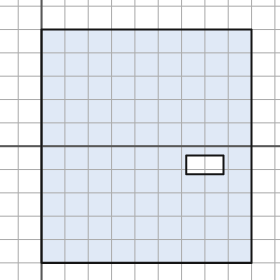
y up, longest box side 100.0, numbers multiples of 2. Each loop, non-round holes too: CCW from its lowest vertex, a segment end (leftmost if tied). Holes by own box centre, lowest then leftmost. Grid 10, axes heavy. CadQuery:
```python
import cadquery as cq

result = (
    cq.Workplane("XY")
    .moveTo(0.0, -50.0)
    .lineTo(90.0, -50.0)
    .lineTo(90.0, 50.0)
    .lineTo(0.0, 50.0)
    .close()
    .moveTo(62.0, -12.0)
    .lineTo(78.0, -12.0)
    .lineTo(78.0, -4.0)
    .lineTo(62.0, -4.0)
    .close()
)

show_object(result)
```